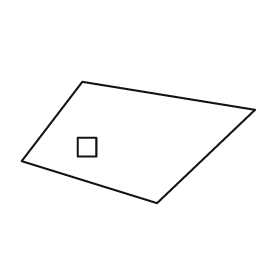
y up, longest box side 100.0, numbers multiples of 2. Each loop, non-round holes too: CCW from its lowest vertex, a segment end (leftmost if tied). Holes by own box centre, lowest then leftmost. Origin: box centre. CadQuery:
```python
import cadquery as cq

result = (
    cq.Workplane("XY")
    .moveTo(8.0, -26.0)
    .lineTo(50.0, 14.0)
    .lineTo(-24.0, 26.0)
    .lineTo(-50.0, -8.0)
    .close()
    .moveTo(-26.0, -6.0)
    .lineTo(-18.0, -6.0)
    .lineTo(-18.0, 2.0)
    .lineTo(-26.0, 2.0)
    .close()
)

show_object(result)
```